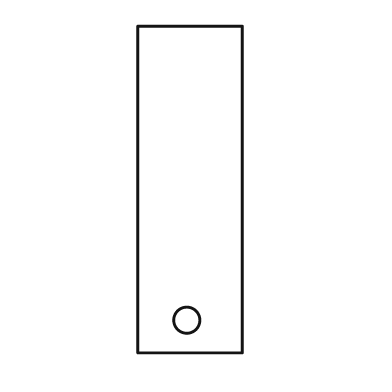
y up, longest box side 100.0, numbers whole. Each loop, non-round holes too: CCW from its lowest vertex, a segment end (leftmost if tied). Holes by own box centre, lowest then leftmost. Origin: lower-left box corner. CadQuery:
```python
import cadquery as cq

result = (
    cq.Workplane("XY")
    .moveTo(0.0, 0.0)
    .lineTo(32.0, 0.0)
    .lineTo(32.0, 100.0)
    .lineTo(0.0, 100.0)
    .close()
    .moveTo(15.0, 10.0)
    .circle(4.0)
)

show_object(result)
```